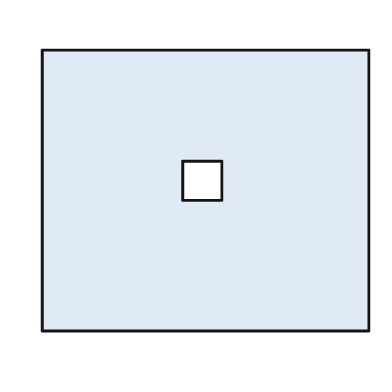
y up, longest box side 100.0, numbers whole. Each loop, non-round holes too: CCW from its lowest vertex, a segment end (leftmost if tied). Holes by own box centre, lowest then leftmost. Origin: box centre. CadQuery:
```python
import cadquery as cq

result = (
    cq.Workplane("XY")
    .moveTo(-50.0, -43.0)
    .lineTo(50.0, -43.0)
    .lineTo(50.0, 43.0)
    .lineTo(-50.0, 43.0)
    .close()
    .moveTo(-7.0, -3.0)
    .lineTo(5.0, -3.0)
    .lineTo(5.0, 9.0)
    .lineTo(-7.0, 9.0)
    .close()
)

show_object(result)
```